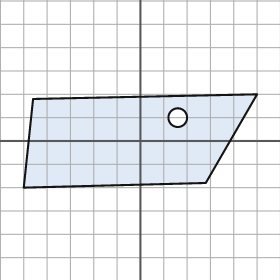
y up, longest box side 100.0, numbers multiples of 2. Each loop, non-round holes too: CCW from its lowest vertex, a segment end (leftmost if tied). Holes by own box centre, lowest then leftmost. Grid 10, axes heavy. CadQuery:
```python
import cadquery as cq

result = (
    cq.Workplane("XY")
    .moveTo(-50.0, -20.0)
    .lineTo(28.0, -18.0)
    .lineTo(50.0, 20.0)
    .lineTo(-46.0, 18.0)
    .close()
    .moveTo(16.0, 10.0)
    .circle(4.0)
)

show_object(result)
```